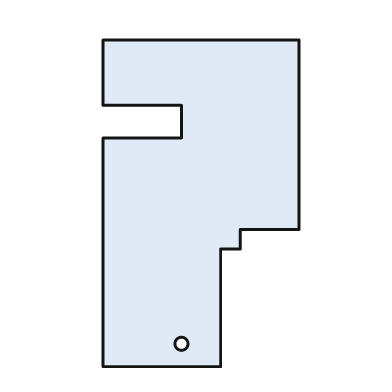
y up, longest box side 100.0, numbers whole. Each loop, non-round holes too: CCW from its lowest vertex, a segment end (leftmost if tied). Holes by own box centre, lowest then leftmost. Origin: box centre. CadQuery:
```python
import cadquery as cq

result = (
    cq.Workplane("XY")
    .moveTo(-30.0, -50.0)
    .lineTo(6.0, -50.0)
    .lineTo(6.0, -14.0)
    .lineTo(12.0, -14.0)
    .lineTo(12.0, -8.0)
    .lineTo(30.0, -8.0)
    .lineTo(30.0, 50.0)
    .lineTo(-30.0, 50.0)
    .lineTo(-30.0, 30.0)
    .lineTo(-6.0, 30.0)
    .lineTo(-6.0, 20.0)
    .lineTo(-30.0, 20.0)
    .close()
    .moveTo(-6.0, -43.0)
    .circle(2.0)
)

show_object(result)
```